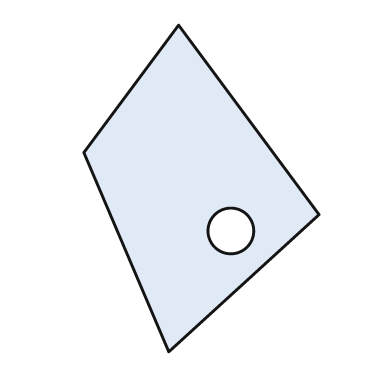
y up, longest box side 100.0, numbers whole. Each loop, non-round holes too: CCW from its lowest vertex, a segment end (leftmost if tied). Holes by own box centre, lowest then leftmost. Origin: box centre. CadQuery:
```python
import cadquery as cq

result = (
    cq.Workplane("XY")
    .moveTo(-10.0, -50.0)
    .lineTo(36.0, -8.0)
    .lineTo(-7.0, 50.0)
    .lineTo(-36.0, 11.0)
    .close()
    .moveTo(9.0, -13.0)
    .circle(7.0)
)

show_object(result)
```